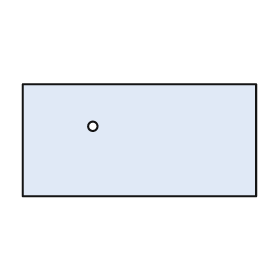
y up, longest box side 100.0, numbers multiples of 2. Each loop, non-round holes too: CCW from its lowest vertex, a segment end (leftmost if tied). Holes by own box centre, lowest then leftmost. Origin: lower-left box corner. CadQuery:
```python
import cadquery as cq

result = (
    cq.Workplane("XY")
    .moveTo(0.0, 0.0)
    .lineTo(100.0, 0.0)
    .lineTo(100.0, 48.0)
    .lineTo(0.0, 48.0)
    .close()
    .moveTo(30.0, 30.0)
    .circle(2.0)
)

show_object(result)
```